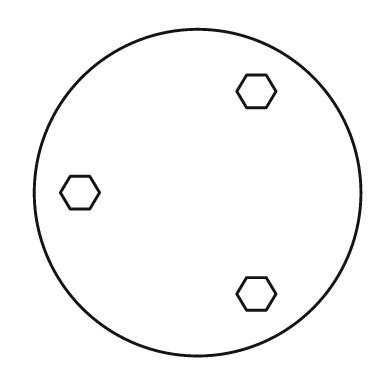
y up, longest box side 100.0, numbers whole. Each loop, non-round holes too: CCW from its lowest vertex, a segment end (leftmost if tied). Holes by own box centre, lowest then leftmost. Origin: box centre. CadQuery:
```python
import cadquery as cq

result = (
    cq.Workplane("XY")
    .moveTo(0.0, 0.0)
    .circle(50.0)
    .moveTo(15.0, -36.0)
    .lineTo(21.0, -36.0)
    .lineTo(24.0, -31.0)
    .lineTo(21.0, -26.0)
    .lineTo(15.0, -26.0)
    .lineTo(12.0, -31.0)
    .close()
    .moveTo(-39.0, -5.0)
    .lineTo(-33.0, -5.0)
    .lineTo(-30.0, 0.0)
    .lineTo(-33.0, 5.0)
    .lineTo(-39.0, 5.0)
    .lineTo(-42.0, 0.0)
    .close()
    .moveTo(15.0, 26.0)
    .lineTo(21.0, 26.0)
    .lineTo(24.0, 31.0)
    .lineTo(21.0, 36.0)
    .lineTo(15.0, 36.0)
    .lineTo(12.0, 31.0)
    .close()
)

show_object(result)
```